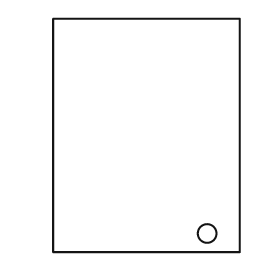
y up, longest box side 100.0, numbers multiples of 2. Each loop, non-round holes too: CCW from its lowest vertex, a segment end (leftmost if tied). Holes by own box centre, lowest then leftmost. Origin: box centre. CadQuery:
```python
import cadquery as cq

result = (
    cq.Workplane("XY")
    .moveTo(-40.0, -50.0)
    .lineTo(40.0, -50.0)
    .lineTo(40.0, 50.0)
    .lineTo(-40.0, 50.0)
    .close()
    .moveTo(26.0, -42.0)
    .circle(4.0)
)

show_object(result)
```